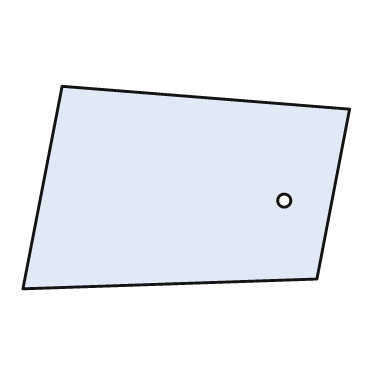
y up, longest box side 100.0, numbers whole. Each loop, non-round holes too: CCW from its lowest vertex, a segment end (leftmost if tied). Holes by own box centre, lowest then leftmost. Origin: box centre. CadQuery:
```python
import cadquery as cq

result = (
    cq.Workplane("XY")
    .moveTo(-50.0, -31.0)
    .lineTo(40.0, -28.0)
    .lineTo(50.0, 24.0)
    .lineTo(-38.0, 31.0)
    .close()
    .moveTo(30.0, -4.0)
    .circle(2.0)
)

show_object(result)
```